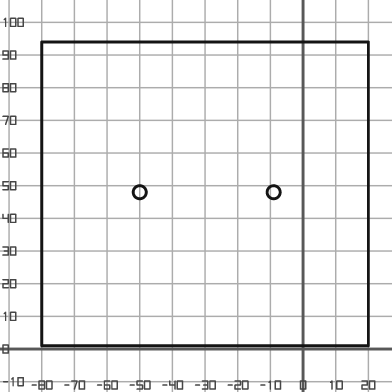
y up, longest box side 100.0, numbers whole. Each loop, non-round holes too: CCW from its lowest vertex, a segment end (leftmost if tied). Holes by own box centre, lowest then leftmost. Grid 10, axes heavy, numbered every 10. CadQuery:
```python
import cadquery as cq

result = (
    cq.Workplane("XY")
    .moveTo(-80.0, 1.0)
    .lineTo(20.0, 1.0)
    .lineTo(20.0, 94.0)
    .lineTo(-80.0, 94.0)
    .close()
    .moveTo(-50.0, 48.0)
    .circle(2.0)
    .moveTo(-9.0, 48.0)
    .circle(2.0)
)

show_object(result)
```